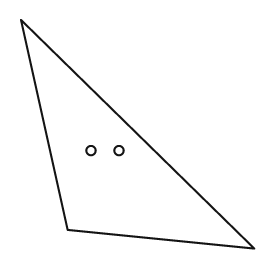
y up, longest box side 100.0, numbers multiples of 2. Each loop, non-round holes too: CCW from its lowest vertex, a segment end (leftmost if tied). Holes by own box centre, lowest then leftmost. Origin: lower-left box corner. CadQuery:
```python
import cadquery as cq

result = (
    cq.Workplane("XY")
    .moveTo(100.0, 0.0)
    .lineTo(0.0, 98.0)
    .lineTo(20.0, 8.0)
    .close()
    .moveTo(30.0, 42.0)
    .circle(2.0)
    .moveTo(42.0, 42.0)
    .circle(2.0)
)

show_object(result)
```